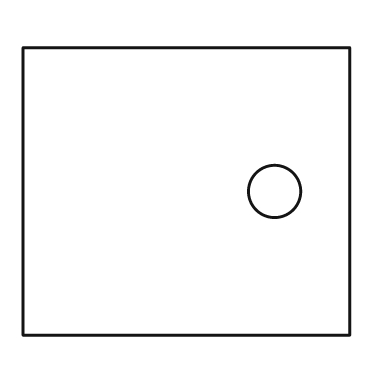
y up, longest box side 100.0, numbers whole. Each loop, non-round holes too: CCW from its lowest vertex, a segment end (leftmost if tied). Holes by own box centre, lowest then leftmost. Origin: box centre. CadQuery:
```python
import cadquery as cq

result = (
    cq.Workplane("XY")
    .moveTo(-50.0, -44.0)
    .lineTo(50.0, -44.0)
    .lineTo(50.0, 44.0)
    .lineTo(-50.0, 44.0)
    .close()
    .moveTo(27.0, 0.0)
    .circle(8.0)
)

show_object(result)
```